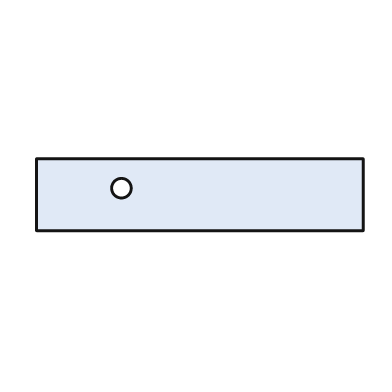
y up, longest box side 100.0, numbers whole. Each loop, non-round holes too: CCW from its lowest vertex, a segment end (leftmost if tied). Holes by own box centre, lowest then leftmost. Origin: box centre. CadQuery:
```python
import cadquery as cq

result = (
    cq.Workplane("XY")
    .moveTo(-50.0, -11.0)
    .lineTo(50.0, -11.0)
    .lineTo(50.0, 11.0)
    .lineTo(-50.0, 11.0)
    .close()
    .moveTo(-24.0, 2.0)
    .circle(3.0)
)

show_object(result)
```